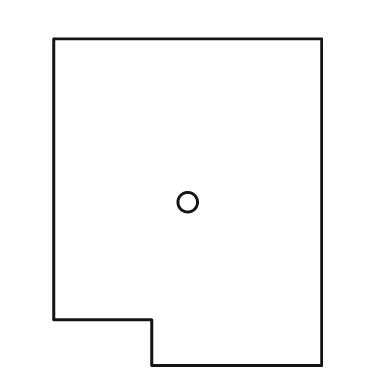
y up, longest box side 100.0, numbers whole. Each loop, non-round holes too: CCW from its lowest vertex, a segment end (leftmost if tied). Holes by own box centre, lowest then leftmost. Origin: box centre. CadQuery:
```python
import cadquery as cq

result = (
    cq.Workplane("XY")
    .moveTo(-11.0, -50.0)
    .lineTo(41.0, -50.0)
    .lineTo(41.0, 50.0)
    .lineTo(-41.0, 50.0)
    .lineTo(-41.0, -36.0)
    .lineTo(-11.0, -36.0)
    .close()
    .moveTo(0.0, 0.0)
    .circle(3.0)
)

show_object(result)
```